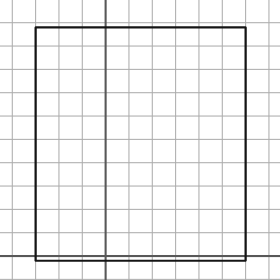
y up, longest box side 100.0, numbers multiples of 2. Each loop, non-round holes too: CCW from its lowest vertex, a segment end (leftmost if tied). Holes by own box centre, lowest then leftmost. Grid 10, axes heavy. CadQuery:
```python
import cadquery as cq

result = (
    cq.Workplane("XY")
    .moveTo(-30.0, -2.0)
    .lineTo(60.0, -2.0)
    .lineTo(60.0, 98.0)
    .lineTo(-30.0, 98.0)
    .close()
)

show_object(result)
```